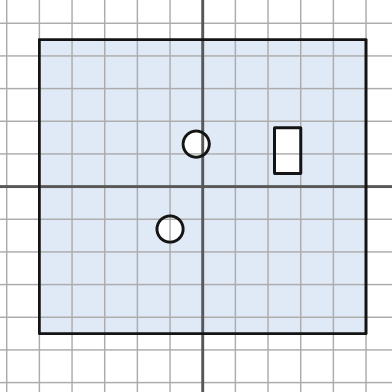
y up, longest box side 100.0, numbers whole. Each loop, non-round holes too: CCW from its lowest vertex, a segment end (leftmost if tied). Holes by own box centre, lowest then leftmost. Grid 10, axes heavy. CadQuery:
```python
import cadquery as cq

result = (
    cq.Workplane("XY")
    .moveTo(-50.0, -45.0)
    .lineTo(50.0, -45.0)
    .lineTo(50.0, 45.0)
    .lineTo(-50.0, 45.0)
    .close()
    .moveTo(-10.0, -13.0)
    .circle(4.0)
    .moveTo(22.0, 4.0)
    .lineTo(30.0, 4.0)
    .lineTo(30.0, 18.0)
    .lineTo(22.0, 18.0)
    .close()
    .moveTo(-2.0, 13.0)
    .circle(4.0)
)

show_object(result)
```